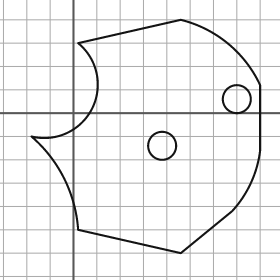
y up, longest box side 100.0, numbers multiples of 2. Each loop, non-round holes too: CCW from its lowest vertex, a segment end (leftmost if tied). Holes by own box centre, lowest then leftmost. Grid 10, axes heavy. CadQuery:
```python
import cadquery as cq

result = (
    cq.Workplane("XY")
    .moveTo(46.0, -60.0)
    .lineTo(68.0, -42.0)
    .threePointArc((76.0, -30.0), (80.0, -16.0))
    .lineTo(80.0, 12.0)
    .threePointArc((66.0, 30.0), (46.0, 40.0))
    .lineTo(2.0, 30.0)
    .threePointArc((8.0, 2.0), (-18.0, -10.0))
    .threePointArc((-4.0, -28.0), (2.0, -50.0))
    .close()
    .moveTo(38.0, -14.0)
    .circle(6.0)
    .moveTo(70.0, 6.0)
    .circle(6.0)
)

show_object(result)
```